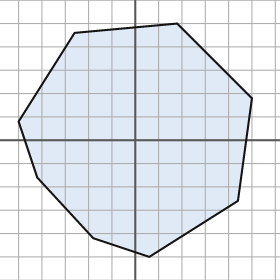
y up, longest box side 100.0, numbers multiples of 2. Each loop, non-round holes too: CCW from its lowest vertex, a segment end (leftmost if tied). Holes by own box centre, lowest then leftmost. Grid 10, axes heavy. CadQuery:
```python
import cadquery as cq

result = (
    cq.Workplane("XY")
    .moveTo(6.0, -50.0)
    .lineTo(44.0, -26.0)
    .lineTo(50.0, 18.0)
    .lineTo(18.0, 50.0)
    .lineTo(-26.0, 46.0)
    .lineTo(-50.0, 8.0)
    .lineTo(-42.0, -16.0)
    .lineTo(-18.0, -42.0)
    .close()
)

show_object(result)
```